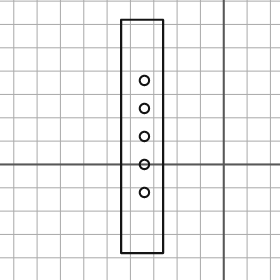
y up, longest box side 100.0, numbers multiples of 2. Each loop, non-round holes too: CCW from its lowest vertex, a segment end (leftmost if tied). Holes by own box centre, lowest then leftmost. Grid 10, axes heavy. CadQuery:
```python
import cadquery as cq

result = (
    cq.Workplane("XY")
    .moveTo(-44.0, -38.0)
    .lineTo(-26.0, -38.0)
    .lineTo(-26.0, 62.0)
    .lineTo(-44.0, 62.0)
    .close()
    .moveTo(-34.0, -12.0)
    .circle(2.0)
    .moveTo(-34.0, 0.0)
    .circle(2.0)
    .moveTo(-34.0, 12.0)
    .circle(2.0)
    .moveTo(-34.0, 24.0)
    .circle(2.0)
    .moveTo(-34.0, 36.0)
    .circle(2.0)
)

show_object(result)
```